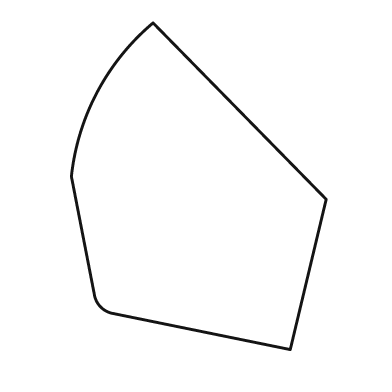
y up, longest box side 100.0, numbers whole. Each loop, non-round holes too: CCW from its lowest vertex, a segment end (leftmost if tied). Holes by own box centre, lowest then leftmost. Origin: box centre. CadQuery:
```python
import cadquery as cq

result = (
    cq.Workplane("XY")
    .moveTo(28.0, -50.0)
    .lineTo(39.0, -4.0)
    .lineTo(-14.0, 50.0)
    .threePointArc((-31.0, 29.0), (-39.0, 3.0))
    .lineTo(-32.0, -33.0)
    .threePointArc((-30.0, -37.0), (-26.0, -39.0))
    .close()
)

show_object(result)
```